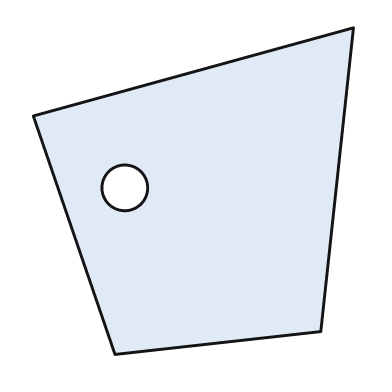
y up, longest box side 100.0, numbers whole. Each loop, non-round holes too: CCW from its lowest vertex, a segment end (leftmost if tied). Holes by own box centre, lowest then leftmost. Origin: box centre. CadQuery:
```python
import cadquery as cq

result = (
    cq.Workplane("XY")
    .moveTo(-24.0, -50.0)
    .lineTo(39.0, -43.0)
    .lineTo(49.0, 50.0)
    .lineTo(-49.0, 23.0)
    .close()
    .moveTo(-21.0, 1.0)
    .circle(7.0)
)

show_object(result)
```